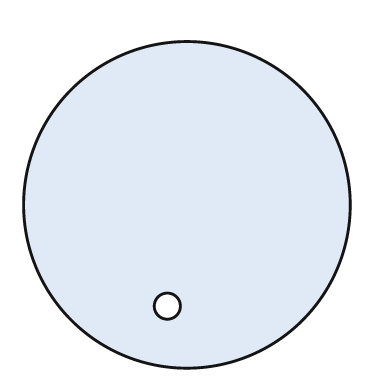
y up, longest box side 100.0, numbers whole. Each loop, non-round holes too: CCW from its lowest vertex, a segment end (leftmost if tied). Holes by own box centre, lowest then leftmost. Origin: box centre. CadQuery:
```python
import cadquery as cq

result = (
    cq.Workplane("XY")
    .moveTo(0.0, 0.0)
    .circle(50.0)
    .moveTo(-6.0, -31.0)
    .circle(4.0)
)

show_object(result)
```